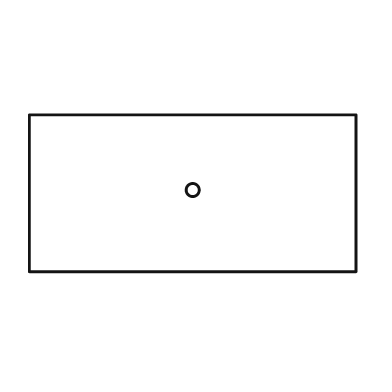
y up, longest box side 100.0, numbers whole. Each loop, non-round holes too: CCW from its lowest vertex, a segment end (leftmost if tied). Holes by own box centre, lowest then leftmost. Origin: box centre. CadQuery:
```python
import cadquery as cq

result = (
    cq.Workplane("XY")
    .moveTo(-50.0, -24.0)
    .lineTo(50.0, -24.0)
    .lineTo(50.0, 24.0)
    .lineTo(-50.0, 24.0)
    .close()
    .moveTo(0.0, 1.0)
    .circle(2.0)
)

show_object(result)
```